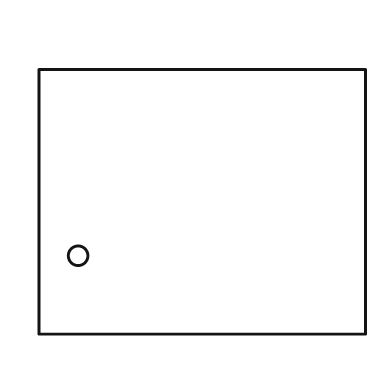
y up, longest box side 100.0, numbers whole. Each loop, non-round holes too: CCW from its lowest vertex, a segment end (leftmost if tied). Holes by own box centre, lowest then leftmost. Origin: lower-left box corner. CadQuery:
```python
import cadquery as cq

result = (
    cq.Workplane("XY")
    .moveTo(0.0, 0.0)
    .lineTo(100.0, 0.0)
    .lineTo(100.0, 81.0)
    .lineTo(0.0, 81.0)
    .close()
    .moveTo(12.0, 24.0)
    .circle(3.0)
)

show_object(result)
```